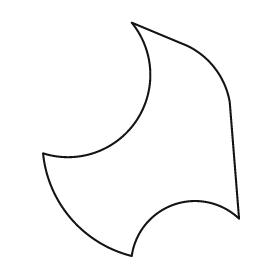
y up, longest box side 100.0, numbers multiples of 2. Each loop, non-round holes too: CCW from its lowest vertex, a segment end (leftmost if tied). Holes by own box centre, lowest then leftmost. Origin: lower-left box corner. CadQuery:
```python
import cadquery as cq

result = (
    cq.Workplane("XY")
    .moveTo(38.0, 0.0)
    .threePointArc((56.0, 22.0), (84.0, 16.0))
    .lineTo(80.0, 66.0)
    .threePointArc((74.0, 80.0), (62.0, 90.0))
    .lineTo(38.0, 100.0)
    .threePointArc((40.0, 58.0), (0.0, 44.0))
    .threePointArc((12.0, 16.0), (38.0, 0.0))
    .close()
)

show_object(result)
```